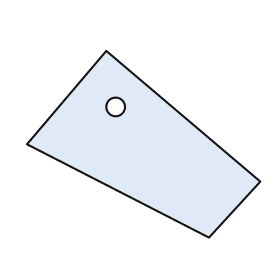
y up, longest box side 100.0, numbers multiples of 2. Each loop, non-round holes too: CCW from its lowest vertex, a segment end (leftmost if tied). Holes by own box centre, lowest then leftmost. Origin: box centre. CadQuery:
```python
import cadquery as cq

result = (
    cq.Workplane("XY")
    .moveTo(28.0, -40.0)
    .lineTo(50.0, -16.0)
    .lineTo(-16.0, 40.0)
    .lineTo(-50.0, 0.0)
    .close()
    .moveTo(-12.0, 16.0)
    .circle(4.0)
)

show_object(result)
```